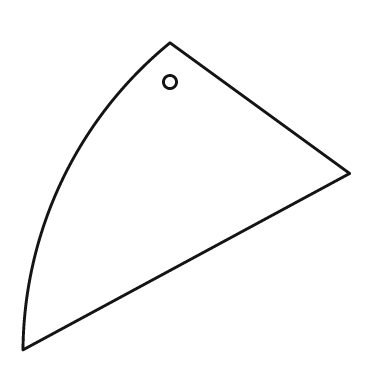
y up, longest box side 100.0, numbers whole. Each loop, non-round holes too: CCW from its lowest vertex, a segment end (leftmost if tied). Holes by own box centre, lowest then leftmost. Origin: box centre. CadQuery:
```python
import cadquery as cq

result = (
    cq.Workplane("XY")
    .moveTo(-50.0, -47.0)
    .lineTo(50.0, 7.0)
    .lineTo(-5.0, 47.0)
    .threePointArc((-38.0, 5.0), (-50.0, -47.0))
    .close()
    .moveTo(-5.0, 35.0)
    .circle(2.0)
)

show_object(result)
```